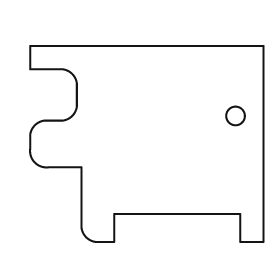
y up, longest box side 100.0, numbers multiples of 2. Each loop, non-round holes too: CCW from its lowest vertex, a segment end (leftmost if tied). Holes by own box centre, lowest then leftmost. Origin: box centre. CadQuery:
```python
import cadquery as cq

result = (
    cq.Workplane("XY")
    .moveTo(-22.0, -42.0)
    .lineTo(-14.0, -42.0)
    .lineTo(-14.0, -30.0)
    .lineTo(40.0, -30.0)
    .lineTo(40.0, -42.0)
    .lineTo(50.0, -42.0)
    .lineTo(50.0, 42.0)
    .lineTo(-50.0, 42.0)
    .lineTo(-50.0, 32.0)
    .lineTo(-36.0, 32.0)
    .threePointArc((-32.0, 30.0), (-30.0, 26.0))
    .lineTo(-30.0, 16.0)
    .threePointArc((-32.0, 12.0), (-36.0, 10.0))
    .lineTo(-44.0, 10.0)
    .threePointArc((-48.0, 8.0), (-50.0, 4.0))
    .lineTo(-50.0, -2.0)
    .threePointArc((-48.0, -8.0), (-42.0, -10.0))
    .lineTo(-28.0, -10.0)
    .lineTo(-28.0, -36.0)
    .threePointArc((-26.0, -40.0), (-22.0, -42.0))
    .close()
    .moveTo(38.0, 12.0)
    .circle(4.0)
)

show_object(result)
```